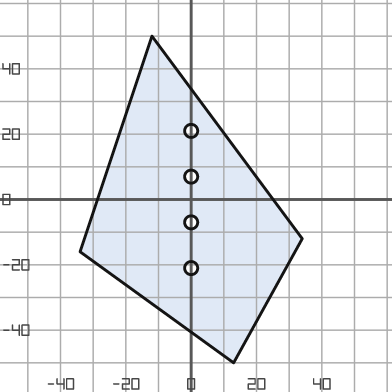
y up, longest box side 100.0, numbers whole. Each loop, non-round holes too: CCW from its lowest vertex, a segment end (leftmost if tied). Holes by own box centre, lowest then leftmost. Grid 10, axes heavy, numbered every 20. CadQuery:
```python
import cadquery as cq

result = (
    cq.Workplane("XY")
    .moveTo(13.0, -50.0)
    .lineTo(34.0, -12.0)
    .lineTo(-12.0, 50.0)
    .lineTo(-34.0, -16.0)
    .close()
    .moveTo(0.0, -21.0)
    .circle(2.0)
    .moveTo(0.0, -7.0)
    .circle(2.0)
    .moveTo(0.0, 7.0)
    .circle(2.0)
    .moveTo(0.0, 21.0)
    .circle(2.0)
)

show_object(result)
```